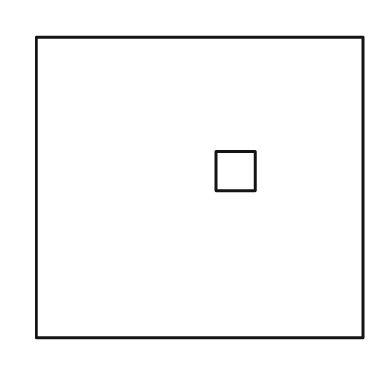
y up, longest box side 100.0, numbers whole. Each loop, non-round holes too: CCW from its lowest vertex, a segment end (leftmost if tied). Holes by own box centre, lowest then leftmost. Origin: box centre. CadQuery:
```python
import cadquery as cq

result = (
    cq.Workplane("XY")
    .moveTo(-50.0, -46.0)
    .lineTo(50.0, -46.0)
    .lineTo(50.0, 46.0)
    .lineTo(-50.0, 46.0)
    .close()
    .moveTo(5.0, -1.0)
    .lineTo(17.0, -1.0)
    .lineTo(17.0, 11.0)
    .lineTo(5.0, 11.0)
    .close()
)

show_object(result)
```